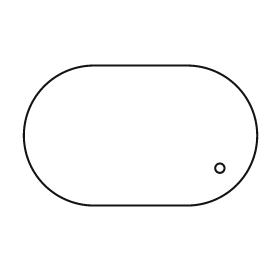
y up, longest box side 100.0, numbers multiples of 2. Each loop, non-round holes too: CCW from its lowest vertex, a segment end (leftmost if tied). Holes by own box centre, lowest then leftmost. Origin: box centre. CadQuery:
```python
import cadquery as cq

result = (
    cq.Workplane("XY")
    .moveTo(-20.0, -30.0)
    .lineTo(20.0, -30.0)
    .threePointArc((50.0, 0.0), (20.0, 30.0))
    .lineTo(-20.0, 30.0)
    .threePointArc((-50.0, 0.0), (-20.0, -30.0))
    .close()
    .moveTo(34.0, -14.0)
    .circle(2.0)
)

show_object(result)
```